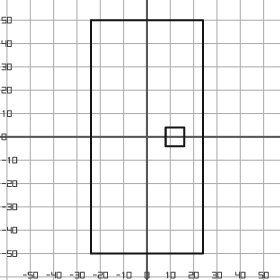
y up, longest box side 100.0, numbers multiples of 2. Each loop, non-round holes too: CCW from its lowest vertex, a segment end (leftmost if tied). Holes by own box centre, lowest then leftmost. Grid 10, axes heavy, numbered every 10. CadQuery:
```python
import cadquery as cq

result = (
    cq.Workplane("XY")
    .moveTo(-24.0, -50.0)
    .lineTo(24.0, -50.0)
    .lineTo(24.0, 50.0)
    .lineTo(-24.0, 50.0)
    .close()
    .moveTo(8.0, -4.0)
    .lineTo(16.0, -4.0)
    .lineTo(16.0, 4.0)
    .lineTo(8.0, 4.0)
    .close()
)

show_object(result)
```